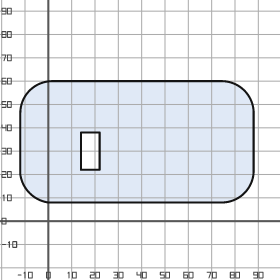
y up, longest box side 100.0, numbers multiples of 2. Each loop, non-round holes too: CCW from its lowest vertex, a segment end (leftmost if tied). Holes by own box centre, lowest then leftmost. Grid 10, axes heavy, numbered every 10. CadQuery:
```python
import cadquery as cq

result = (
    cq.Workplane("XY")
    .moveTo(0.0, 8.0)
    .lineTo(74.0, 8.0)
    .threePointArc((84.0, 12.0), (88.0, 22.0))
    .lineTo(88.0, 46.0)
    .threePointArc((84.0, 56.0), (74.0, 60.0))
    .lineTo(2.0, 60.0)
    .threePointArc((-8.0, 56.0), (-12.0, 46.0))
    .lineTo(-12.0, 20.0)
    .threePointArc((-8.0, 12.0), (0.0, 8.0))
    .close()
    .moveTo(14.0, 22.0)
    .lineTo(22.0, 22.0)
    .lineTo(22.0, 38.0)
    .lineTo(14.0, 38.0)
    .close()
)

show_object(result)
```